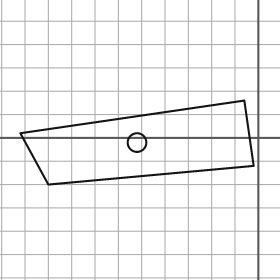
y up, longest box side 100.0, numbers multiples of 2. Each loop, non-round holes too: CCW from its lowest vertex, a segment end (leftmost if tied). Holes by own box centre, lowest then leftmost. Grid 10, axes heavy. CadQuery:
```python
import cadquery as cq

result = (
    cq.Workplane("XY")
    .moveTo(-90.0, -20.0)
    .lineTo(-2.0, -12.0)
    .lineTo(-6.0, 16.0)
    .lineTo(-102.0, 2.0)
    .close()
    .moveTo(-52.0, -2.0)
    .circle(4.0)
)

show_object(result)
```